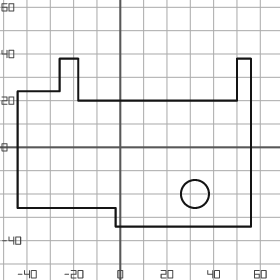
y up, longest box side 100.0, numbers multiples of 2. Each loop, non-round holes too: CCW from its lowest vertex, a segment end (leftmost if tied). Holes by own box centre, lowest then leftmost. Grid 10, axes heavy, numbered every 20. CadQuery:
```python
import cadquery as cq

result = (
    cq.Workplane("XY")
    .moveTo(-2.0, -34.0)
    .lineTo(56.0, -34.0)
    .lineTo(56.0, 38.0)
    .lineTo(50.0, 38.0)
    .lineTo(50.0, 20.0)
    .lineTo(-18.0, 20.0)
    .lineTo(-18.0, 38.0)
    .lineTo(-26.0, 38.0)
    .lineTo(-26.0, 24.0)
    .lineTo(-44.0, 24.0)
    .lineTo(-44.0, -26.0)
    .lineTo(-2.0, -26.0)
    .close()
    .moveTo(32.0, -20.0)
    .circle(6.0)
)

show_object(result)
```